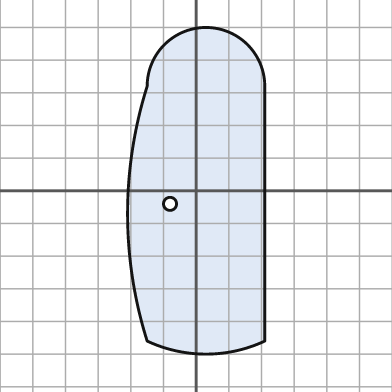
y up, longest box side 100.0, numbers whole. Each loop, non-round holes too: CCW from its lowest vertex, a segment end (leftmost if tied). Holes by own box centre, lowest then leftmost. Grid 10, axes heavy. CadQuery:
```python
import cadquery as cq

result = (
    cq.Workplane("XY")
    .moveTo(-15.0, -46.0)
    .threePointArc((3.0, -50.0), (21.0, -46.0))
    .lineTo(21.0, 32.0)
    .threePointArc((3.0, 50.0), (-15.0, 32.0))
    .threePointArc((-21.0, -7.0), (-15.0, -46.0))
    .close()
    .moveTo(-8.0, -4.0)
    .circle(2.0)
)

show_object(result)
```